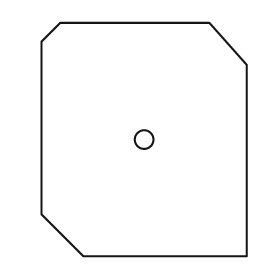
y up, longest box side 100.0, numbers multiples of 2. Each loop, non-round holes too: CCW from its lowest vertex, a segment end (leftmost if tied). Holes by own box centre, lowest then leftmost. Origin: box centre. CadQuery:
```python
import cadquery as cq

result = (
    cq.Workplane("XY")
    .moveTo(-26.0, -50.0)
    .lineTo(44.0, -50.0)
    .lineTo(44.0, 32.0)
    .lineTo(28.0, 50.0)
    .lineTo(-36.0, 50.0)
    .lineTo(-44.0, 42.0)
    .lineTo(-44.0, -32.0)
    .close()
    .moveTo(0.0, 0.0)
    .circle(4.0)
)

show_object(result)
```